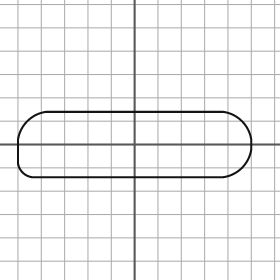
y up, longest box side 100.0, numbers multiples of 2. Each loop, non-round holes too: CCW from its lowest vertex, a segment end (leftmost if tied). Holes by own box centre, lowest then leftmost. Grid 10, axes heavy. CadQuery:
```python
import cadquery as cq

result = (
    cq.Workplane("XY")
    .moveTo(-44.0, -14.0)
    .lineTo(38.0, -14.0)
    .threePointArc((46.0, -10.0), (50.0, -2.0))
    .lineTo(50.0, 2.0)
    .threePointArc((46.0, 10.0), (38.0, 14.0))
    .lineTo(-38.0, 14.0)
    .threePointArc((-46.0, 10.0), (-50.0, 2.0))
    .lineTo(-50.0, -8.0)
    .threePointArc((-48.0, -12.0), (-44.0, -14.0))
    .close()
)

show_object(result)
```